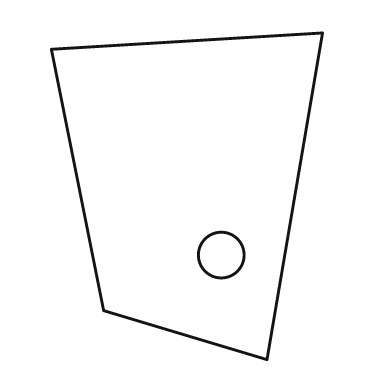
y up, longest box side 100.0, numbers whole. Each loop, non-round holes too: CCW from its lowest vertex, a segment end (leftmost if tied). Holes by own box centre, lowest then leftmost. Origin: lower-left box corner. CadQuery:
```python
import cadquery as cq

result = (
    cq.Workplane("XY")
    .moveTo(66.0, 0.0)
    .lineTo(83.0, 100.0)
    .lineTo(0.0, 95.0)
    .lineTo(16.0, 15.0)
    .close()
    .moveTo(52.0, 32.0)
    .circle(7.0)
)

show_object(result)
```